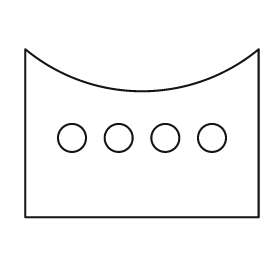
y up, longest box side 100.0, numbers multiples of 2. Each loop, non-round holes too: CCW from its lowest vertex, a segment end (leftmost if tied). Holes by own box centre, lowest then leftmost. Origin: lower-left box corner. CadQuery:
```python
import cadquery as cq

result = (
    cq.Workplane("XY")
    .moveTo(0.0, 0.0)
    .lineTo(100.0, 0.0)
    .lineTo(100.0, 72.0)
    .threePointArc((50.0, 54.0), (0.0, 72.0))
    .close()
    .moveTo(20.0, 34.0)
    .circle(6.0)
    .moveTo(40.0, 34.0)
    .circle(6.0)
    .moveTo(60.0, 34.0)
    .circle(6.0)
    .moveTo(80.0, 34.0)
    .circle(6.0)
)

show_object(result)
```